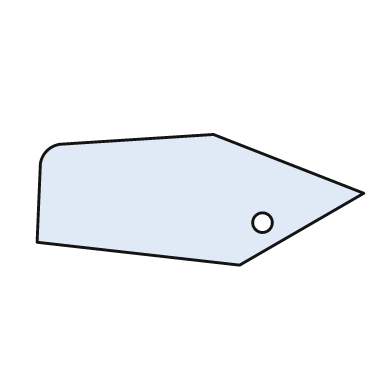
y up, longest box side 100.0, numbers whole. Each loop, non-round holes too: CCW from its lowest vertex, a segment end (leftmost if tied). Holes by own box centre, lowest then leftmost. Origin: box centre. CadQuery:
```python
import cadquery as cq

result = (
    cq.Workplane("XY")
    .moveTo(12.0, -20.0)
    .lineTo(50.0, 2.0)
    .lineTo(4.0, 20.0)
    .lineTo(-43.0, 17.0)
    .threePointArc((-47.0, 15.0), (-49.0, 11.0))
    .lineTo(-50.0, -13.0)
    .close()
    .moveTo(19.0, -7.0)
    .circle(3.0)
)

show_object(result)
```